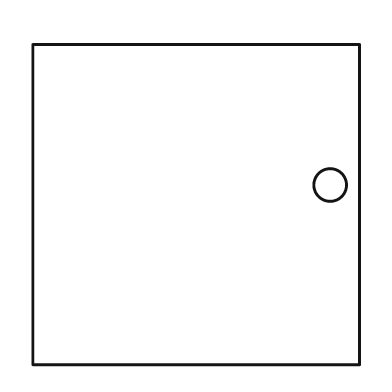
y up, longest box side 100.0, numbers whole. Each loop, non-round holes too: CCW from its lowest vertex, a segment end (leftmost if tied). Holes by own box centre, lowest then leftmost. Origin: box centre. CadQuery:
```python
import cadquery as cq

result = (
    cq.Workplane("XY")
    .moveTo(-50.0, -49.0)
    .lineTo(50.0, -49.0)
    .lineTo(50.0, 49.0)
    .lineTo(-50.0, 49.0)
    .close()
    .moveTo(41.0, 6.0)
    .circle(5.0)
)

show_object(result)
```